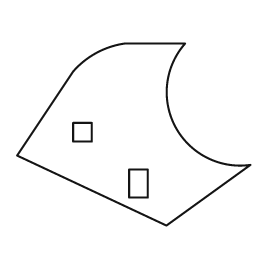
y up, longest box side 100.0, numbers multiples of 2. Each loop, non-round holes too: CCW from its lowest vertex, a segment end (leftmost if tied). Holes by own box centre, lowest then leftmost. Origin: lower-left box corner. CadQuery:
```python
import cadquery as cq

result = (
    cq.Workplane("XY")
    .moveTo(64.0, 0.0)
    .lineTo(100.0, 26.0)
    .threePointArc((68.0, 42.0), (72.0, 78.0))
    .lineTo(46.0, 78.0)
    .threePointArc((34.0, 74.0), (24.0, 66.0))
    .lineTo(0.0, 30.0)
    .close()
    .moveTo(48.0, 12.0)
    .lineTo(56.0, 12.0)
    .lineTo(56.0, 24.0)
    .lineTo(48.0, 24.0)
    .close()
    .moveTo(24.0, 36.0)
    .lineTo(32.0, 36.0)
    .lineTo(32.0, 44.0)
    .lineTo(24.0, 44.0)
    .close()
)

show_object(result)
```